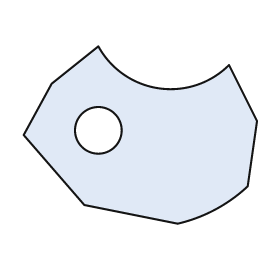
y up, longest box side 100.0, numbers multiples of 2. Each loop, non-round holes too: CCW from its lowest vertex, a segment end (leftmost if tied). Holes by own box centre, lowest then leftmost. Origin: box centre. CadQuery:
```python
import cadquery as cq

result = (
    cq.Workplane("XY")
    .moveTo(16.0, -38.0)
    .threePointArc((32.0, -32.0), (46.0, -22.0))
    .lineTo(50.0, 6.0)
    .lineTo(38.0, 30.0)
    .threePointArc((8.0, 20.0), (-18.0, 38.0))
    .lineTo(-38.0, 22.0)
    .lineTo(-50.0, 0.0)
    .lineTo(-24.0, -30.0)
    .close()
    .moveTo(-18.0, 2.0)
    .circle(10.0)
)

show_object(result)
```